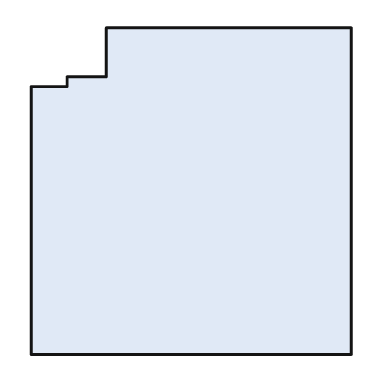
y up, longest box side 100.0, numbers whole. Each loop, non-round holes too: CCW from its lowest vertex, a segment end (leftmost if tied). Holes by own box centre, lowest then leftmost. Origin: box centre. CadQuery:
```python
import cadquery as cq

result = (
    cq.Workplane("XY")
    .moveTo(-49.0, -50.0)
    .lineTo(49.0, -50.0)
    .lineTo(49.0, 50.0)
    .lineTo(-26.0, 50.0)
    .lineTo(-26.0, 35.0)
    .lineTo(-38.0, 35.0)
    .lineTo(-38.0, 32.0)
    .lineTo(-49.0, 32.0)
    .close()
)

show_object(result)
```